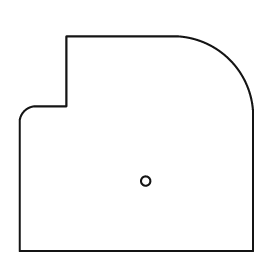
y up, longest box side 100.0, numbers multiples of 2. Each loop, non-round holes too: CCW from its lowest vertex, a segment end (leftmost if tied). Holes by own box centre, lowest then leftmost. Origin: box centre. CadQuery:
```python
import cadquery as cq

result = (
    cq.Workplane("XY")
    .moveTo(-50.0, -46.0)
    .lineTo(50.0, -46.0)
    .lineTo(50.0, 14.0)
    .threePointArc((40.0, 36.0), (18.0, 46.0))
    .lineTo(-30.0, 46.0)
    .lineTo(-30.0, 16.0)
    .lineTo(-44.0, 16.0)
    .threePointArc((-48.0, 14.0), (-50.0, 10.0))
    .close()
    .moveTo(4.0, -16.0)
    .circle(2.0)
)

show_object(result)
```